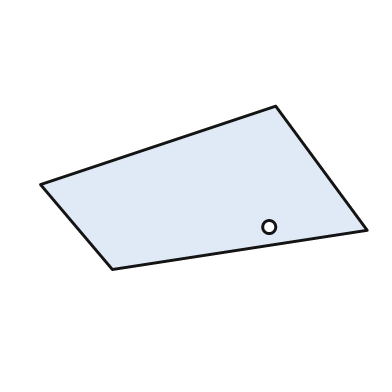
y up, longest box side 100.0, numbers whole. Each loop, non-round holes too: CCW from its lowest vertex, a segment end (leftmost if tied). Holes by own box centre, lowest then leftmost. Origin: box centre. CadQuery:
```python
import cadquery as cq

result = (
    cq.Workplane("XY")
    .moveTo(-28.0, -25.0)
    .lineTo(50.0, -13.0)
    .lineTo(22.0, 25.0)
    .lineTo(-50.0, 1.0)
    .close()
    .moveTo(20.0, -12.0)
    .circle(2.0)
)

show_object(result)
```